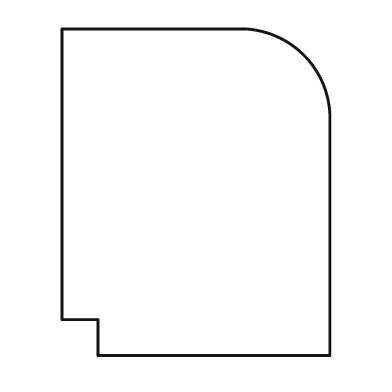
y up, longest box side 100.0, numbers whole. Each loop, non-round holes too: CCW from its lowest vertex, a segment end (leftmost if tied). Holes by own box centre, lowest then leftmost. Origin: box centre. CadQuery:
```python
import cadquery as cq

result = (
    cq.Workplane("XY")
    .moveTo(-30.0, -50.0)
    .lineTo(41.0, -50.0)
    .lineTo(41.0, 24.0)
    .threePointArc((33.0, 42.0), (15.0, 50.0))
    .lineTo(-41.0, 50.0)
    .lineTo(-41.0, -39.0)
    .lineTo(-30.0, -39.0)
    .close()
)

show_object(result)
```